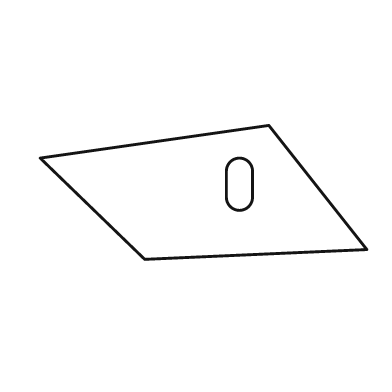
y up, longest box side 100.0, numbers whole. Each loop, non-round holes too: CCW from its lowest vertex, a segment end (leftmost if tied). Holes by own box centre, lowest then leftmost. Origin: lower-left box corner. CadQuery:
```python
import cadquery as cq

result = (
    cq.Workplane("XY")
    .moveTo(32.0, 0.0)
    .lineTo(100.0, 3.0)
    .lineTo(70.0, 41.0)
    .lineTo(0.0, 31.0)
    .close()
    .moveTo(57.0, 19.0)
    .threePointArc((61.0, 15.0), (65.0, 19.0))
    .lineTo(65.0, 27.0)
    .threePointArc((61.0, 31.0), (57.0, 27.0))
    .close()
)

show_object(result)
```